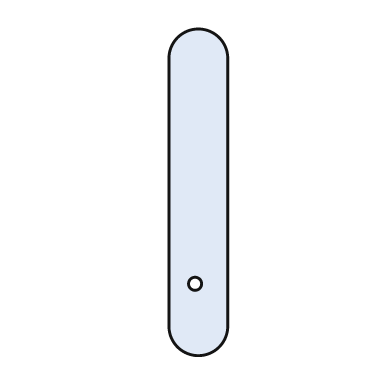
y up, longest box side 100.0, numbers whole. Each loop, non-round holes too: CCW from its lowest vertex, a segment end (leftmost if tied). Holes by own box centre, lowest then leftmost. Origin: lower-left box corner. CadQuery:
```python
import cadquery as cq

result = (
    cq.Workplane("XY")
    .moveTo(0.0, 9.0)
    .threePointArc((9.0, 0.0), (18.0, 9.0))
    .lineTo(18.0, 91.0)
    .threePointArc((9.0, 100.0), (0.0, 91.0))
    .close()
    .moveTo(8.0, 22.0)
    .circle(2.0)
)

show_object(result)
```